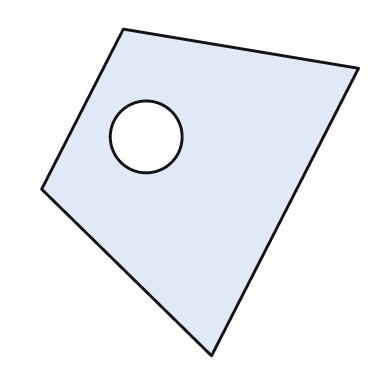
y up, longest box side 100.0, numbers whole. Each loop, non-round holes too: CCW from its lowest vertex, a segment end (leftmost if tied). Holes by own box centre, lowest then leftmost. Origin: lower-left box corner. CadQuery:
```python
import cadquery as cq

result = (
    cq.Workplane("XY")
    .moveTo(52.0, 0.0)
    .lineTo(97.0, 88.0)
    .lineTo(25.0, 100.0)
    .lineTo(0.0, 51.0)
    .close()
    .moveTo(32.0, 67.0)
    .circle(11.0)
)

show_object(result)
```